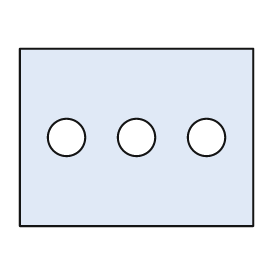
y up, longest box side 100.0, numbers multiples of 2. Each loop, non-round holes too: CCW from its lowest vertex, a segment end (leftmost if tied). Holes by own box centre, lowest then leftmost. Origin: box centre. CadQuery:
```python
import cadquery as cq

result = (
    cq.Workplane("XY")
    .moveTo(-50.0, -38.0)
    .lineTo(50.0, -38.0)
    .lineTo(50.0, 38.0)
    .lineTo(-50.0, 38.0)
    .close()
    .moveTo(-30.0, 0.0)
    .circle(8.0)
    .moveTo(0.0, 0.0)
    .circle(8.0)
    .moveTo(30.0, 0.0)
    .circle(8.0)
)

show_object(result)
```